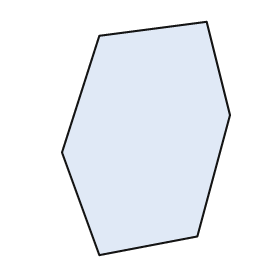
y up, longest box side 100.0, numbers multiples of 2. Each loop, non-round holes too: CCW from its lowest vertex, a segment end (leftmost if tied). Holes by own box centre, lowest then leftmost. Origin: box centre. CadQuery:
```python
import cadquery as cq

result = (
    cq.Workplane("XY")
    .moveTo(-20.0, -50.0)
    .lineTo(22.0, -42.0)
    .lineTo(36.0, 10.0)
    .lineTo(26.0, 50.0)
    .lineTo(-20.0, 44.0)
    .lineTo(-36.0, -6.0)
    .close()
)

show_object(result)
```